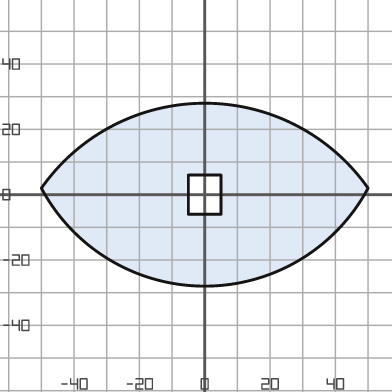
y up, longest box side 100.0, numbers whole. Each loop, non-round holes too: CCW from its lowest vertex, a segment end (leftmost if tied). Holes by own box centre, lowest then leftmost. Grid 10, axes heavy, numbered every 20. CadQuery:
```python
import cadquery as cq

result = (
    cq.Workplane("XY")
    .moveTo(-50.0, 2.0)
    .threePointArc((0.0, -28.0), (50.0, 2.0))
    .threePointArc((0.0, 28.0), (-50.0, 2.0))
    .close()
    .moveTo(-5.0, -6.0)
    .lineTo(5.0, -6.0)
    .lineTo(5.0, 6.0)
    .lineTo(-5.0, 6.0)
    .close()
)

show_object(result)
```